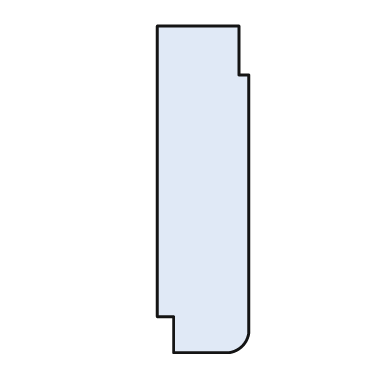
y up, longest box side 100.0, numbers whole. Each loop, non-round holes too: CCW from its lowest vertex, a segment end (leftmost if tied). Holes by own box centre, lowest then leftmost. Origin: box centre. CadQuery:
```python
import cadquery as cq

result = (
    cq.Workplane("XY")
    .moveTo(-9.0, -50.0)
    .lineTo(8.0, -50.0)
    .threePointArc((12.0, -48.0), (14.0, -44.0))
    .lineTo(14.0, 35.0)
    .lineTo(11.0, 35.0)
    .lineTo(11.0, 50.0)
    .lineTo(-14.0, 50.0)
    .lineTo(-14.0, -39.0)
    .lineTo(-9.0, -39.0)
    .close()
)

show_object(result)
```